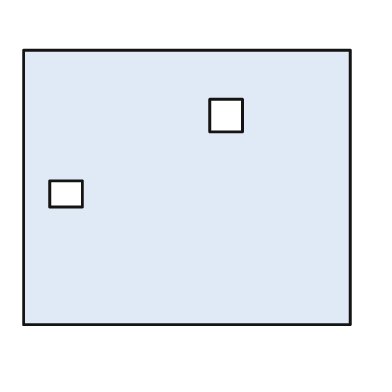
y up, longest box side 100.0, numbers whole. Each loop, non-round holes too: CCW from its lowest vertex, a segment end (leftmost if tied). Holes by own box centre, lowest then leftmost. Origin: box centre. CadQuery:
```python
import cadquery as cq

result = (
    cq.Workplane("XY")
    .moveTo(-50.0, -42.0)
    .lineTo(50.0, -42.0)
    .lineTo(50.0, 42.0)
    .lineTo(-50.0, 42.0)
    .close()
    .moveTo(-42.0, -6.0)
    .lineTo(-32.0, -6.0)
    .lineTo(-32.0, 2.0)
    .lineTo(-42.0, 2.0)
    .close()
    .moveTo(7.0, 17.0)
    .lineTo(17.0, 17.0)
    .lineTo(17.0, 27.0)
    .lineTo(7.0, 27.0)
    .close()
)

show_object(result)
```